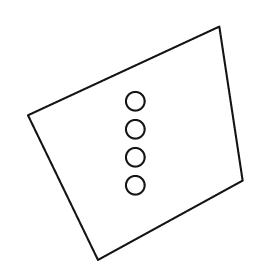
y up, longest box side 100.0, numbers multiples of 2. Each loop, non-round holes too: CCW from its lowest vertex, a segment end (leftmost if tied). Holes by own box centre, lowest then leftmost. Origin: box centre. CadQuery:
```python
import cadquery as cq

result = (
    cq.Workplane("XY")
    .moveTo(-16.0, -50.0)
    .lineTo(46.0, -16.0)
    .lineTo(36.0, 50.0)
    .lineTo(-46.0, 12.0)
    .close()
    .moveTo(0.0, -18.0)
    .circle(4.0)
    .moveTo(0.0, -6.0)
    .circle(4.0)
    .moveTo(0.0, 6.0)
    .circle(4.0)
    .moveTo(0.0, 18.0)
    .circle(4.0)
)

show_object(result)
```